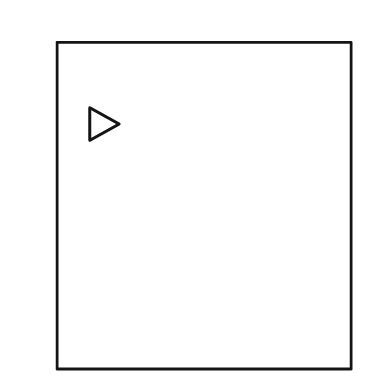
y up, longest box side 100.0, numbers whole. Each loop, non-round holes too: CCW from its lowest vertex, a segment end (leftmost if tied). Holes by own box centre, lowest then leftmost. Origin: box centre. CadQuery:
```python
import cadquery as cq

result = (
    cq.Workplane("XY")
    .moveTo(-45.0, -50.0)
    .lineTo(45.0, -50.0)
    .lineTo(45.0, 50.0)
    .lineTo(-45.0, 50.0)
    .close()
    .moveTo(-35.0, 20.0)
    .lineTo(-26.0, 25.0)
    .lineTo(-35.0, 30.0)
    .close()
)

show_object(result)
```